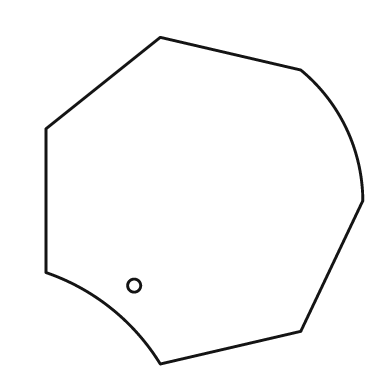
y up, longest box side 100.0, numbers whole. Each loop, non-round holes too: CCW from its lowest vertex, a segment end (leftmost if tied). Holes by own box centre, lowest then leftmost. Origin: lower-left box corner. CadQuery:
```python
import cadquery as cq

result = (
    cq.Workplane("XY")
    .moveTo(35.0, 0.0)
    .lineTo(78.0, 10.0)
    .lineTo(97.0, 50.0)
    .threePointArc((92.0, 72.0), (78.0, 90.0))
    .lineTo(35.0, 100.0)
    .lineTo(0.0, 72.0)
    .lineTo(0.0, 28.0)
    .threePointArc((20.0, 17.0), (35.0, 0.0))
    .close()
    .moveTo(27.0, 24.0)
    .circle(2.0)
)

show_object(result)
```